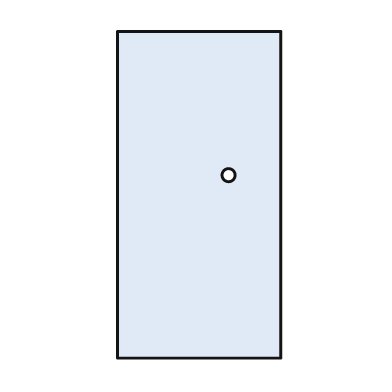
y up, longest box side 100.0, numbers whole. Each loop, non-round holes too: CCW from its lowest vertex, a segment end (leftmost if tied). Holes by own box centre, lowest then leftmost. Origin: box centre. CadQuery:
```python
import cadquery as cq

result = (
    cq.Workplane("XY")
    .moveTo(-25.0, -50.0)
    .lineTo(25.0, -50.0)
    .lineTo(25.0, 50.0)
    .lineTo(-25.0, 50.0)
    .close()
    .moveTo(9.0, 6.0)
    .circle(2.0)
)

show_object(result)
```